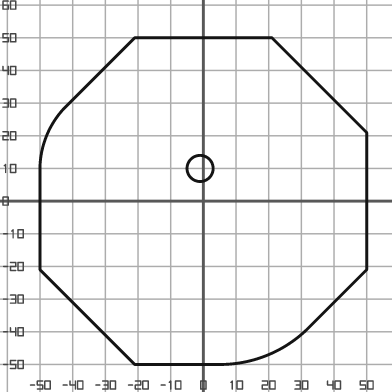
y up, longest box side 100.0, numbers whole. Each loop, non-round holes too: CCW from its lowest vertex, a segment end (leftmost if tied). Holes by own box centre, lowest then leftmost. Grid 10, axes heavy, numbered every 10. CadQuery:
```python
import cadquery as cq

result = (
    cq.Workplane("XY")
    .moveTo(-21.0, -50.0)
    .lineTo(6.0, -50.0)
    .threePointArc((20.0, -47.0), (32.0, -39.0))
    .lineTo(50.0, -21.0)
    .lineTo(50.0, 21.0)
    .lineTo(21.0, 50.0)
    .lineTo(-21.0, 50.0)
    .lineTo(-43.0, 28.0)
    .threePointArc((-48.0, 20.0), (-50.0, 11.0))
    .lineTo(-50.0, -21.0)
    .close()
    .moveTo(-1.0, 10.0)
    .circle(4.0)
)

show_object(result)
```